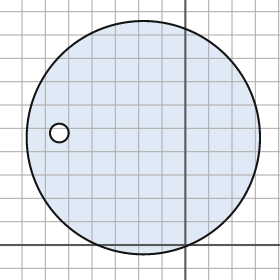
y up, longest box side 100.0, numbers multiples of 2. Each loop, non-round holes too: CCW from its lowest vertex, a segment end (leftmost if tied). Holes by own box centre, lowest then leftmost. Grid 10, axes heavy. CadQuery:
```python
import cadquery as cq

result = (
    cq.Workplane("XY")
    .moveTo(-18.0, 46.0)
    .circle(50.0)
    .moveTo(-54.0, 48.0)
    .circle(4.0)
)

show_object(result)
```